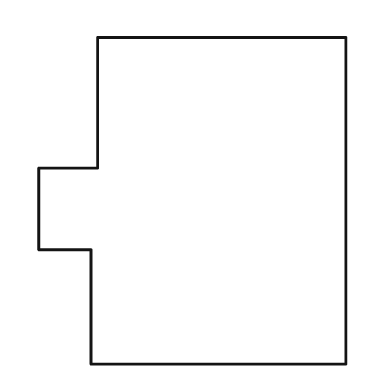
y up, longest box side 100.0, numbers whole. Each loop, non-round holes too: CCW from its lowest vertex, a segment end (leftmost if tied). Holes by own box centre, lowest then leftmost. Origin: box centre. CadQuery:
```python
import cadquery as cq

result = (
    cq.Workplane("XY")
    .moveTo(-31.0, -50.0)
    .lineTo(47.0, -50.0)
    .lineTo(47.0, 50.0)
    .lineTo(-29.0, 50.0)
    .lineTo(-29.0, 10.0)
    .lineTo(-47.0, 10.0)
    .lineTo(-47.0, -15.0)
    .lineTo(-31.0, -15.0)
    .close()
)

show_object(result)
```